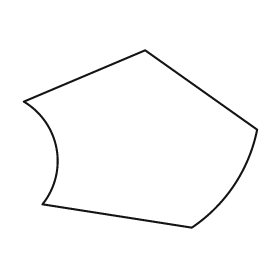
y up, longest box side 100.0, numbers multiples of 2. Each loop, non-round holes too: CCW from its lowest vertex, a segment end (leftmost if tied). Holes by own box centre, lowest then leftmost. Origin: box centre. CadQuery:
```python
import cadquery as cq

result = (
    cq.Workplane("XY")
    .moveTo(22.0, -38.0)
    .threePointArc((40.0, -20.0), (50.0, 4.0))
    .lineTo(2.0, 38.0)
    .lineTo(-50.0, 16.0)
    .threePointArc((-36.0, -4.0), (-42.0, -28.0))
    .close()
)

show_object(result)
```